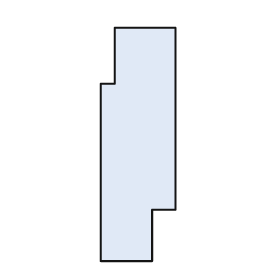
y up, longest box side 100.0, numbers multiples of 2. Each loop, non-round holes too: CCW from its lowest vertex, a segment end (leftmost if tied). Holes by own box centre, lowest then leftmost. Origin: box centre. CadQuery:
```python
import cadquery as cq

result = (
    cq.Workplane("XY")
    .moveTo(-16.0, -50.0)
    .lineTo(6.0, -50.0)
    .lineTo(6.0, -28.0)
    .lineTo(16.0, -28.0)
    .lineTo(16.0, 50.0)
    .lineTo(-10.0, 50.0)
    .lineTo(-10.0, 26.0)
    .lineTo(-16.0, 26.0)
    .close()
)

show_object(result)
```